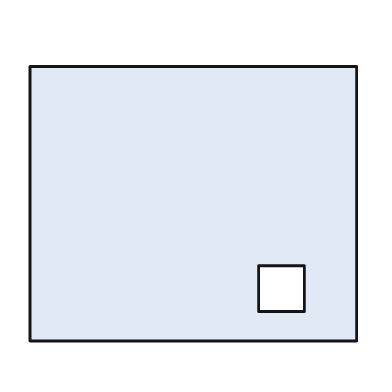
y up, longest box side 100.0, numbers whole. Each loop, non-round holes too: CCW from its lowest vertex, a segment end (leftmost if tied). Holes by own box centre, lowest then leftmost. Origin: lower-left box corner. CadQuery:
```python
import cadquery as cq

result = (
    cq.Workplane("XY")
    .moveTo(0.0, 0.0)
    .lineTo(100.0, 0.0)
    .lineTo(100.0, 84.0)
    .lineTo(0.0, 84.0)
    .close()
    .moveTo(70.0, 9.0)
    .lineTo(84.0, 9.0)
    .lineTo(84.0, 23.0)
    .lineTo(70.0, 23.0)
    .close()
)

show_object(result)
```